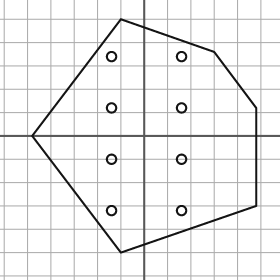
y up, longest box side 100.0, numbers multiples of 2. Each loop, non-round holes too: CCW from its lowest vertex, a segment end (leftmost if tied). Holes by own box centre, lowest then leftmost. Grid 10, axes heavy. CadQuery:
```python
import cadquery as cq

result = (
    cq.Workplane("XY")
    .moveTo(-10.0, -50.0)
    .lineTo(48.0, -30.0)
    .lineTo(48.0, 12.0)
    .lineTo(30.0, 36.0)
    .lineTo(-10.0, 50.0)
    .lineTo(-48.0, 0.0)
    .close()
    .moveTo(-14.0, -32.0)
    .circle(2.0)
    .moveTo(16.0, -32.0)
    .circle(2.0)
    .moveTo(-14.0, -10.0)
    .circle(2.0)
    .moveTo(16.0, -10.0)
    .circle(2.0)
    .moveTo(-14.0, 12.0)
    .circle(2.0)
    .moveTo(16.0, 12.0)
    .circle(2.0)
    .moveTo(-14.0, 34.0)
    .circle(2.0)
    .moveTo(16.0, 34.0)
    .circle(2.0)
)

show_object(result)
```